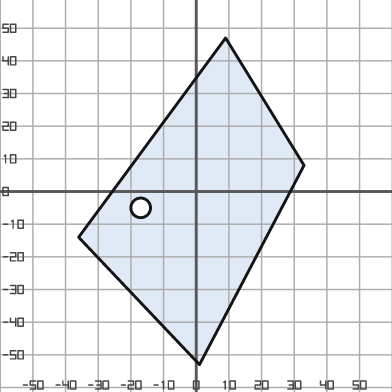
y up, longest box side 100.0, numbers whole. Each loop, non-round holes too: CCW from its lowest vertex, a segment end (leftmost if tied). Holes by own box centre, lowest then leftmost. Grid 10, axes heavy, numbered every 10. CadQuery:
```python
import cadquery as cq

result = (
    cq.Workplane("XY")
    .moveTo(1.0, -53.0)
    .lineTo(33.0, 8.0)
    .lineTo(9.0, 47.0)
    .lineTo(-36.0, -14.0)
    .close()
    .moveTo(-17.0, -5.0)
    .circle(3.0)
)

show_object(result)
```